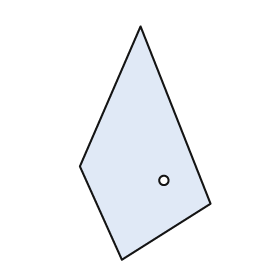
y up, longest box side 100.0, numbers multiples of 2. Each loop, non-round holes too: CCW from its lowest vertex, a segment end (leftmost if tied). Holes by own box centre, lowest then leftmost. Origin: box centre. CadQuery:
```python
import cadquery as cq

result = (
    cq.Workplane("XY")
    .moveTo(-10.0, -50.0)
    .lineTo(28.0, -26.0)
    .lineTo(-2.0, 50.0)
    .lineTo(-28.0, -10.0)
    .close()
    .moveTo(8.0, -16.0)
    .circle(2.0)
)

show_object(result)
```